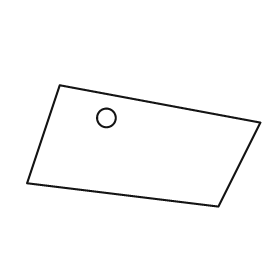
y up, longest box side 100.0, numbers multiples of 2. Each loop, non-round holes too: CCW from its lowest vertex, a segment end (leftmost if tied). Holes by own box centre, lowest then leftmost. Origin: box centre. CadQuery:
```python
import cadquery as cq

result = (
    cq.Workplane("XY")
    .moveTo(32.0, -26.0)
    .lineTo(50.0, 10.0)
    .lineTo(-36.0, 26.0)
    .lineTo(-50.0, -16.0)
    .close()
    .moveTo(-16.0, 12.0)
    .circle(4.0)
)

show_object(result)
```